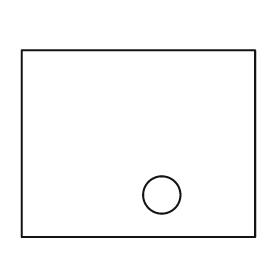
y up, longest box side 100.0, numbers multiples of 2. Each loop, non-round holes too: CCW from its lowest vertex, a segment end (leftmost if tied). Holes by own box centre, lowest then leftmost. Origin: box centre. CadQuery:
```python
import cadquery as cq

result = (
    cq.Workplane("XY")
    .moveTo(-50.0, -40.0)
    .lineTo(50.0, -40.0)
    .lineTo(50.0, 40.0)
    .lineTo(-50.0, 40.0)
    .close()
    .moveTo(10.0, -22.0)
    .circle(8.0)
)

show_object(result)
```